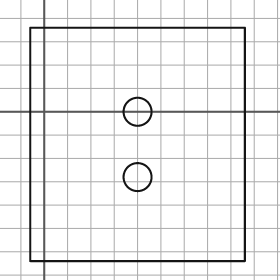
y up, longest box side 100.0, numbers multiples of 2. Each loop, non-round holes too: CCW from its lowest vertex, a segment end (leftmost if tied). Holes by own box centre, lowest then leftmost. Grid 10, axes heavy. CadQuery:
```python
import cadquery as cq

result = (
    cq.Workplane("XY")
    .moveTo(-6.0, -64.0)
    .lineTo(86.0, -64.0)
    .lineTo(86.0, 36.0)
    .lineTo(-6.0, 36.0)
    .close()
    .moveTo(40.0, -28.0)
    .circle(6.0)
    .moveTo(40.0, 0.0)
    .circle(6.0)
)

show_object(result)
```